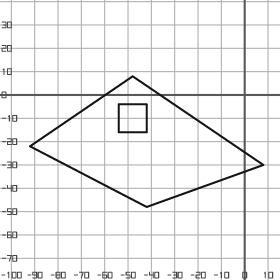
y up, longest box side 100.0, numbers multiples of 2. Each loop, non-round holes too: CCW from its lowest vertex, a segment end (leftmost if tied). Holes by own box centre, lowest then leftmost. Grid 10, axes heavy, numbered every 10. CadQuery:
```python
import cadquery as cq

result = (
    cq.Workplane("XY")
    .moveTo(-42.0, -48.0)
    .lineTo(8.0, -30.0)
    .lineTo(-48.0, 8.0)
    .lineTo(-92.0, -22.0)
    .close()
    .moveTo(-54.0, -16.0)
    .lineTo(-42.0, -16.0)
    .lineTo(-42.0, -4.0)
    .lineTo(-54.0, -4.0)
    .close()
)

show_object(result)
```